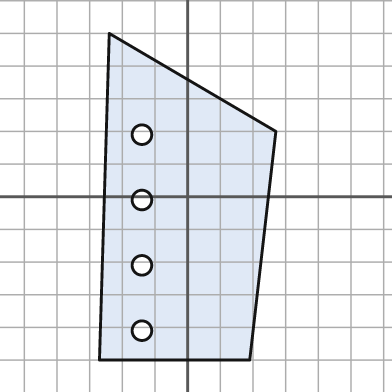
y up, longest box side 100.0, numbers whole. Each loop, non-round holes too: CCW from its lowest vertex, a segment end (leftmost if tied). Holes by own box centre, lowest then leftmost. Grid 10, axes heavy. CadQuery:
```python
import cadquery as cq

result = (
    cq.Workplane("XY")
    .moveTo(-27.0, -50.0)
    .lineTo(19.0, -50.0)
    .lineTo(27.0, 20.0)
    .lineTo(-24.0, 50.0)
    .close()
    .moveTo(-14.0, -41.0)
    .circle(3.0)
    .moveTo(-14.0, -21.0)
    .circle(3.0)
    .moveTo(-14.0, -1.0)
    .circle(3.0)
    .moveTo(-14.0, 19.0)
    .circle(3.0)
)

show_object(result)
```